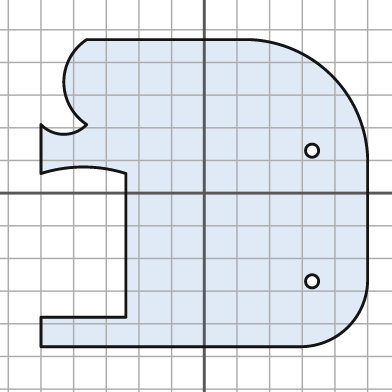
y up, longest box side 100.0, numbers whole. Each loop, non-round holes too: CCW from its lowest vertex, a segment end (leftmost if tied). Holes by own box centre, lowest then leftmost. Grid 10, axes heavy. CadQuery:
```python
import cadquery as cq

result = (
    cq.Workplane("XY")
    .moveTo(-50.0, -47.0)
    .lineTo(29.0, -47.0)
    .threePointArc((44.0, -41.0), (50.0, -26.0))
    .lineTo(50.0, 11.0)
    .threePointArc((39.0, 36.0), (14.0, 47.0))
    .lineTo(-36.0, 47.0)
    .threePointArc((-43.0, 34.0), (-36.0, 21.0))
    .threePointArc((-43.0, 18.0), (-50.0, 21.0))
    .lineTo(-50.0, 6.0)
    .threePointArc((-37.0, 8.0), (-24.0, 6.0))
    .lineTo(-24.0, -38.0)
    .lineTo(-50.0, -38.0)
    .close()
    .moveTo(33.0, -27.0)
    .circle(2.0)
    .moveTo(33.0, 13.0)
    .circle(2.0)
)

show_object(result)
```